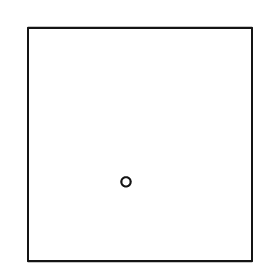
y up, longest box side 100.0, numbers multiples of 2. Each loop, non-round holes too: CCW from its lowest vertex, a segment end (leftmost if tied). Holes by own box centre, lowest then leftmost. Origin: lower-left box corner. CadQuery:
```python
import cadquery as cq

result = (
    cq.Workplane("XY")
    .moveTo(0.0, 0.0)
    .lineTo(96.0, 0.0)
    .lineTo(96.0, 100.0)
    .lineTo(0.0, 100.0)
    .close()
    .moveTo(42.0, 34.0)
    .circle(2.0)
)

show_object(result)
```